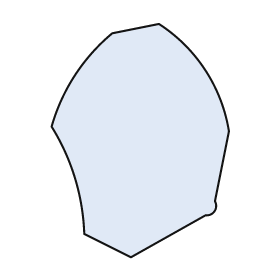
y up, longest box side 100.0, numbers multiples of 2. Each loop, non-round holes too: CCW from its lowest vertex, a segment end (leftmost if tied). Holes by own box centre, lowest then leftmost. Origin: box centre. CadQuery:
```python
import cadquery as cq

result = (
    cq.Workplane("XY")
    .moveTo(-4.0, -50.0)
    .lineTo(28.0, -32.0)
    .threePointArc((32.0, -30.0), (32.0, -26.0))
    .lineTo(38.0, 4.0)
    .threePointArc((28.0, 30.0), (8.0, 50.0))
    .lineTo(-12.0, 46.0)
    .threePointArc((-28.0, 28.0), (-38.0, 6.0))
    .threePointArc((-28.0, -16.0), (-24.0, -40.0))
    .close()
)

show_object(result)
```